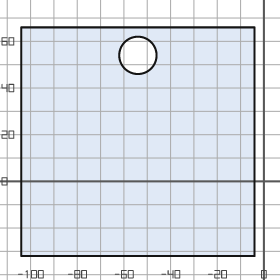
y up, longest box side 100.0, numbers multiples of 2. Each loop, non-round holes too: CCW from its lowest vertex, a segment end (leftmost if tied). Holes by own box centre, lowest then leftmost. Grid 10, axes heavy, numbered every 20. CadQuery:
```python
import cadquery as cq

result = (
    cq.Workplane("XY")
    .moveTo(-104.0, -32.0)
    .lineTo(-4.0, -32.0)
    .lineTo(-4.0, 66.0)
    .lineTo(-104.0, 66.0)
    .close()
    .moveTo(-54.0, 54.0)
    .circle(8.0)
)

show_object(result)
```